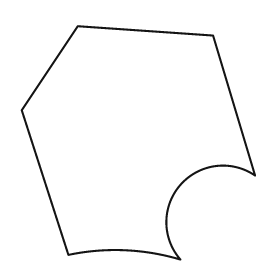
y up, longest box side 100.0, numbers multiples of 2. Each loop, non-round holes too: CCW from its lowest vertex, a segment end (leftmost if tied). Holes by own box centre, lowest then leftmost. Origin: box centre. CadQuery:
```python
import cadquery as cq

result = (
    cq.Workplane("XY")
    .moveTo(18.0, -50.0)
    .threePointArc((18.0, -18.0), (50.0, -14.0))
    .lineTo(32.0, 46.0)
    .lineTo(-26.0, 50.0)
    .lineTo(-50.0, 14.0)
    .lineTo(-30.0, -48.0)
    .threePointArc((-6.0, -46.0), (18.0, -50.0))
    .close()
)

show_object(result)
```